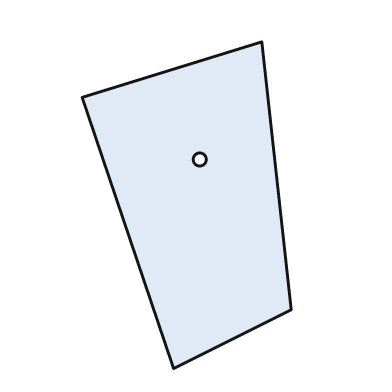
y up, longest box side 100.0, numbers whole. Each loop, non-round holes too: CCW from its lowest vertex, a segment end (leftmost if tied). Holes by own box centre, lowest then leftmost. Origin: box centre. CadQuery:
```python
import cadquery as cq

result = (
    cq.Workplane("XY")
    .moveTo(-4.0, -50.0)
    .lineTo(32.0, -32.0)
    .lineTo(23.0, 50.0)
    .lineTo(-32.0, 33.0)
    .close()
    .moveTo(4.0, 14.0)
    .circle(2.0)
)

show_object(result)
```